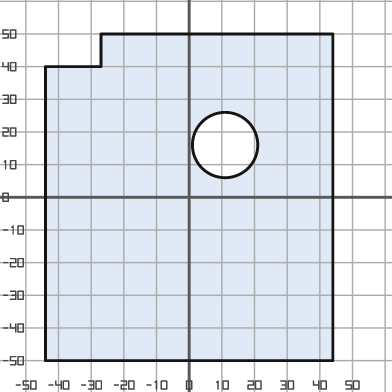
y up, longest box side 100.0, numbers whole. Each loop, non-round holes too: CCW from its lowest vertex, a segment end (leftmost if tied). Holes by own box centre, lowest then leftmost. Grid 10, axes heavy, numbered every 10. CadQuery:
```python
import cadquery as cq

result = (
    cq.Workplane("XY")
    .moveTo(-44.0, -50.0)
    .lineTo(44.0, -50.0)
    .lineTo(44.0, 50.0)
    .lineTo(-27.0, 50.0)
    .lineTo(-27.0, 40.0)
    .lineTo(-44.0, 40.0)
    .close()
    .moveTo(11.0, 16.0)
    .circle(10.0)
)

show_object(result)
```